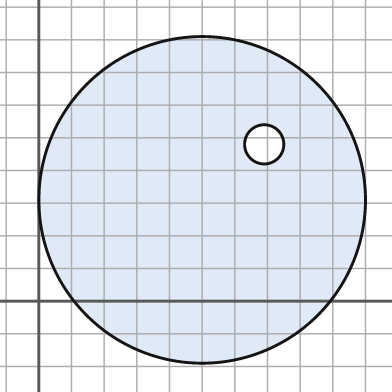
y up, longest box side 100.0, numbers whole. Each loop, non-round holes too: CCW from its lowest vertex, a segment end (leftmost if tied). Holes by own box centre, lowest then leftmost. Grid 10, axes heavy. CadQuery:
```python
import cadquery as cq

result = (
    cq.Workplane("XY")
    .moveTo(50.0, 31.0)
    .circle(50.0)
    .moveTo(69.0, 48.0)
    .circle(6.0)
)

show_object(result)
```